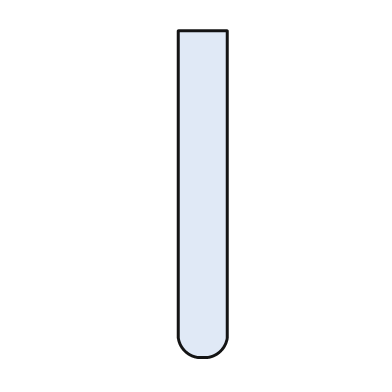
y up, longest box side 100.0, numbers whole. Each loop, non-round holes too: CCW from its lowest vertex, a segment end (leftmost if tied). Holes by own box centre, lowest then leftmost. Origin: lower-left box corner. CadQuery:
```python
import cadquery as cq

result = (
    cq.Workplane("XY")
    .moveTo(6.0, 0.0)
    .lineTo(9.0, 0.0)
    .threePointArc((13.0, 2.0), (15.0, 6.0))
    .lineTo(15.0, 100.0)
    .lineTo(0.0, 100.0)
    .lineTo(0.0, 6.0)
    .threePointArc((2.0, 2.0), (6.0, 0.0))
    .close()
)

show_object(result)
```